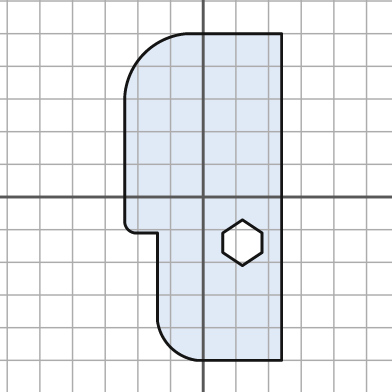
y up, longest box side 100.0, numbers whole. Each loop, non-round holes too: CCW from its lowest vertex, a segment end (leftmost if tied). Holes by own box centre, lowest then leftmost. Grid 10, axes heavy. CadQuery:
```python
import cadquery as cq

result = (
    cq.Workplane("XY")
    .moveTo(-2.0, -50.0)
    .lineTo(24.0, -50.0)
    .lineTo(24.0, 50.0)
    .lineTo(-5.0, 50.0)
    .threePointArc((-18.0, 44.0), (-24.0, 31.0))
    .lineTo(-24.0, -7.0)
    .threePointArc((-23.0, -10.0), (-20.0, -11.0))
    .lineTo(-14.0, -11.0)
    .lineTo(-14.0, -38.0)
    .threePointArc((-10.0, -46.0), (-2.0, -50.0))
    .close()
    .moveTo(12.0, -21.0)
    .lineTo(18.0, -17.0)
    .lineTo(18.0, -11.0)
    .lineTo(12.0, -7.0)
    .lineTo(6.0, -11.0)
    .lineTo(6.0, -17.0)
    .close()
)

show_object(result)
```